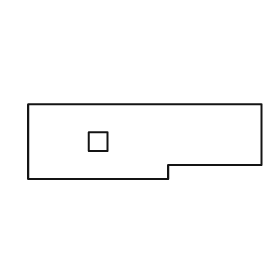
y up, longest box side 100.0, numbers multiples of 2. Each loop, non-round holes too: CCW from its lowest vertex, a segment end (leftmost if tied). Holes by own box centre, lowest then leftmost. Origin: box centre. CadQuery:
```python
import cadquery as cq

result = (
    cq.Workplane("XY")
    .moveTo(-50.0, -16.0)
    .lineTo(10.0, -16.0)
    .lineTo(10.0, -10.0)
    .lineTo(50.0, -10.0)
    .lineTo(50.0, 16.0)
    .lineTo(-50.0, 16.0)
    .close()
    .moveTo(-24.0, -4.0)
    .lineTo(-16.0, -4.0)
    .lineTo(-16.0, 4.0)
    .lineTo(-24.0, 4.0)
    .close()
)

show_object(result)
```